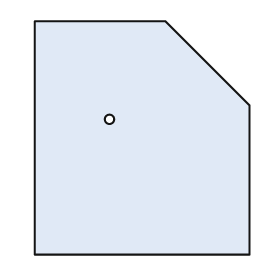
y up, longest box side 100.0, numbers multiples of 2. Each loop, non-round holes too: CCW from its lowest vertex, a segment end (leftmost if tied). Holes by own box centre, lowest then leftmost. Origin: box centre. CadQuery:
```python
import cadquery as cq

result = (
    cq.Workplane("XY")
    .moveTo(-46.0, -50.0)
    .lineTo(46.0, -50.0)
    .lineTo(46.0, 14.0)
    .lineTo(10.0, 50.0)
    .lineTo(-46.0, 50.0)
    .close()
    .moveTo(-14.0, 8.0)
    .circle(2.0)
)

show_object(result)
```